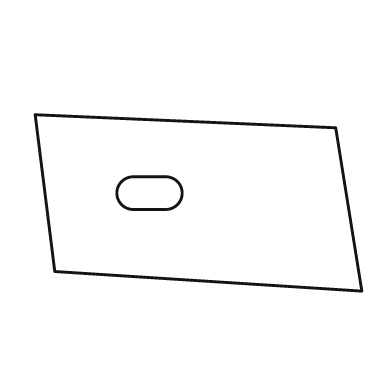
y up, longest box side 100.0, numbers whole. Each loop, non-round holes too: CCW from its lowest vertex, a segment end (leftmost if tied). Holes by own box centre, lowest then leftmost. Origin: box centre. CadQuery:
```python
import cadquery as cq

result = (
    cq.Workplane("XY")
    .moveTo(50.0, -27.0)
    .lineTo(42.0, 23.0)
    .lineTo(-50.0, 27.0)
    .lineTo(-44.0, -21.0)
    .close()
    .moveTo(-20.0, -2.0)
    .lineTo(-10.0, -2.0)
    .threePointArc((-5.0, 3.0), (-10.0, 8.0))
    .lineTo(-20.0, 8.0)
    .threePointArc((-25.0, 3.0), (-20.0, -2.0))
    .close()
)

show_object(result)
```